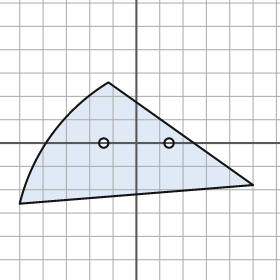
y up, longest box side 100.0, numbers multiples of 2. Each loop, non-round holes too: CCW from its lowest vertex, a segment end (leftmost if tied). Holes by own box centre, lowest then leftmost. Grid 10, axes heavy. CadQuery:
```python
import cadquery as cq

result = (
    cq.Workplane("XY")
    .moveTo(-50.0, -26.0)
    .lineTo(50.0, -18.0)
    .lineTo(-12.0, 26.0)
    .threePointArc((-36.0, 4.0), (-50.0, -26.0))
    .close()
    .moveTo(-14.0, 0.0)
    .circle(2.0)
    .moveTo(14.0, 0.0)
    .circle(2.0)
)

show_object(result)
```